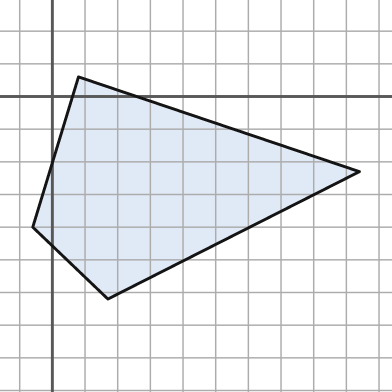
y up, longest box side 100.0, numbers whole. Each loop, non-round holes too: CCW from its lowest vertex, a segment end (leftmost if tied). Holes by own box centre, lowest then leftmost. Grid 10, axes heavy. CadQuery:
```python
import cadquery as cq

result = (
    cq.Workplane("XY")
    .moveTo(17.0, -62.0)
    .lineTo(94.0, -23.0)
    .lineTo(8.0, 6.0)
    .lineTo(-6.0, -40.0)
    .close()
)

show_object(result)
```